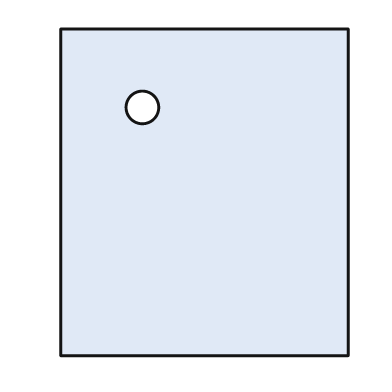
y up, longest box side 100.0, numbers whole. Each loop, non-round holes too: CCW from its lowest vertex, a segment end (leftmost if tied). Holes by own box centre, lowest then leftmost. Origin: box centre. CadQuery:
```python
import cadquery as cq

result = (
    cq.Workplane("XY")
    .moveTo(-44.0, -50.0)
    .lineTo(44.0, -50.0)
    .lineTo(44.0, 50.0)
    .lineTo(-44.0, 50.0)
    .close()
    .moveTo(-19.0, 26.0)
    .circle(5.0)
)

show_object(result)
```